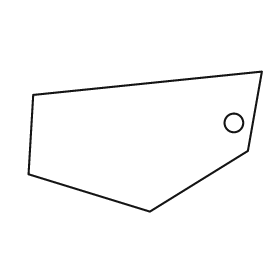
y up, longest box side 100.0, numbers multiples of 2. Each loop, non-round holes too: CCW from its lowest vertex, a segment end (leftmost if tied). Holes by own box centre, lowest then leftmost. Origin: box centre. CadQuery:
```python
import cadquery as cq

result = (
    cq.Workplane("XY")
    .moveTo(2.0, -30.0)
    .lineTo(44.0, -4.0)
    .lineTo(50.0, 30.0)
    .lineTo(-48.0, 20.0)
    .lineTo(-50.0, -14.0)
    .close()
    .moveTo(38.0, 8.0)
    .circle(4.0)
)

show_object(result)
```